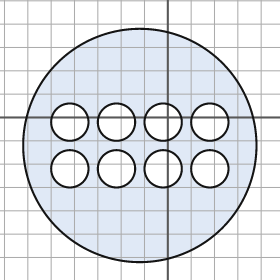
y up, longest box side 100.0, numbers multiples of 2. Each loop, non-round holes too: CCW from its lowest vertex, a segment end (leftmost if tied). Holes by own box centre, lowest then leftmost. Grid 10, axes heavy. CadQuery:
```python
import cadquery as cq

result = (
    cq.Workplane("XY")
    .moveTo(-12.0, -12.0)
    .circle(50.0)
    .moveTo(-42.0, -22.0)
    .circle(8.0)
    .moveTo(-22.0, -22.0)
    .circle(8.0)
    .moveTo(-2.0, -22.0)
    .circle(8.0)
    .moveTo(18.0, -22.0)
    .circle(8.0)
    .moveTo(-42.0, -2.0)
    .circle(8.0)
    .moveTo(-22.0, -2.0)
    .circle(8.0)
    .moveTo(-2.0, -2.0)
    .circle(8.0)
    .moveTo(18.0, -2.0)
    .circle(8.0)
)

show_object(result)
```